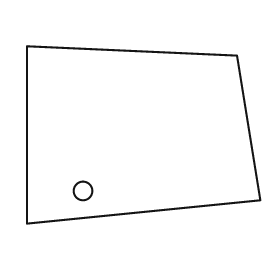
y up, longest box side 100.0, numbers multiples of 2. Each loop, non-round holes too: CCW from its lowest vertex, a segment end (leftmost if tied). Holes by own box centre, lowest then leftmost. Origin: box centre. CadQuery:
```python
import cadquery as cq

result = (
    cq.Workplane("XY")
    .moveTo(-50.0, -38.0)
    .lineTo(50.0, -28.0)
    .lineTo(40.0, 34.0)
    .lineTo(-50.0, 38.0)
    .close()
    .moveTo(-26.0, -24.0)
    .circle(4.0)
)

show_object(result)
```